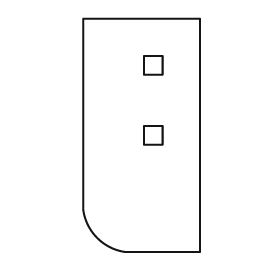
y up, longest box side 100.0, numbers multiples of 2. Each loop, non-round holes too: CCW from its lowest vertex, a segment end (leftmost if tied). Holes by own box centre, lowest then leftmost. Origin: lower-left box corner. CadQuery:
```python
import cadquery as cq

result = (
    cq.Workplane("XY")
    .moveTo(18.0, 0.0)
    .lineTo(50.0, 0.0)
    .lineTo(50.0, 100.0)
    .lineTo(0.0, 100.0)
    .lineTo(0.0, 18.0)
    .threePointArc((6.0, 6.0), (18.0, 0.0))
    .close()
    .moveTo(26.0, 46.0)
    .lineTo(34.0, 46.0)
    .lineTo(34.0, 54.0)
    .lineTo(26.0, 54.0)
    .close()
    .moveTo(26.0, 76.0)
    .lineTo(34.0, 76.0)
    .lineTo(34.0, 84.0)
    .lineTo(26.0, 84.0)
    .close()
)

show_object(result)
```